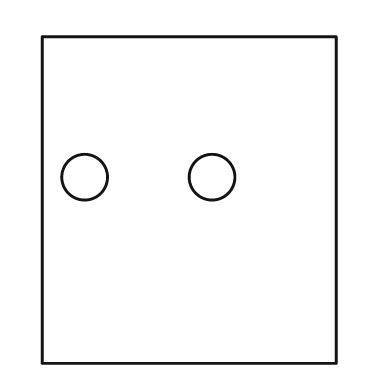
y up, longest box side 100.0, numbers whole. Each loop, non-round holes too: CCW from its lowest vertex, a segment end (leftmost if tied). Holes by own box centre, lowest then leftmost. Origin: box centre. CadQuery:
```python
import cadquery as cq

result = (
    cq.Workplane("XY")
    .moveTo(-45.0, -50.0)
    .lineTo(45.0, -50.0)
    .lineTo(45.0, 50.0)
    .lineTo(-45.0, 50.0)
    .close()
    .moveTo(-32.0, 7.0)
    .circle(7.0)
    .moveTo(7.0, 7.0)
    .circle(7.0)
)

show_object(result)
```